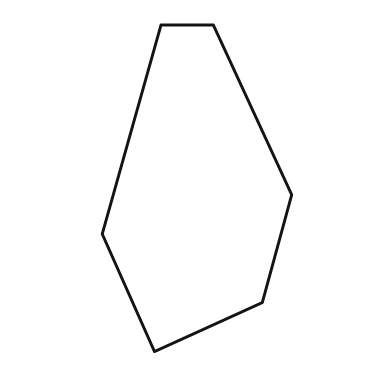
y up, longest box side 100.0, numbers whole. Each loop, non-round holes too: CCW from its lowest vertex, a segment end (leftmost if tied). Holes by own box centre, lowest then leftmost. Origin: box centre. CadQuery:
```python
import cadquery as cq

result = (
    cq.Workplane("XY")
    .moveTo(-13.0, -50.0)
    .lineTo(20.0, -35.0)
    .lineTo(29.0, -2.0)
    .lineTo(5.0, 50.0)
    .lineTo(-11.0, 50.0)
    .lineTo(-29.0, -14.0)
    .close()
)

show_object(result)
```